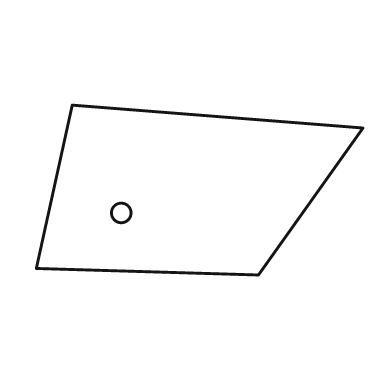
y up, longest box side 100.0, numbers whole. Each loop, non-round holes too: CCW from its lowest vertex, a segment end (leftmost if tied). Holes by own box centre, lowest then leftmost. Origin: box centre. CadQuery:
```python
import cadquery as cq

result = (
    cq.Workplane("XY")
    .moveTo(18.0, -26.0)
    .lineTo(50.0, 19.0)
    .lineTo(-39.0, 26.0)
    .lineTo(-50.0, -24.0)
    .close()
    .moveTo(-24.0, -7.0)
    .circle(3.0)
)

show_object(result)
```